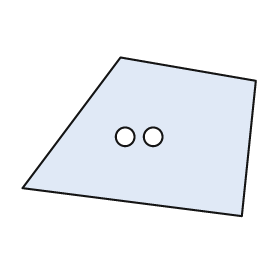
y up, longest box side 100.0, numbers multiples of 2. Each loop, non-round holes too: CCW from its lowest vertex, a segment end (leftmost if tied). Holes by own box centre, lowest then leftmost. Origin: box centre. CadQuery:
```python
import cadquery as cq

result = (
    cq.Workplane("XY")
    .moveTo(44.0, -34.0)
    .lineTo(50.0, 24.0)
    .lineTo(-8.0, 34.0)
    .lineTo(-50.0, -22.0)
    .close()
    .moveTo(-6.0, 0.0)
    .circle(4.0)
    .moveTo(6.0, 0.0)
    .circle(4.0)
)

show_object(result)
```